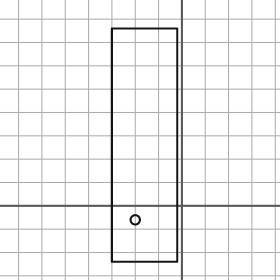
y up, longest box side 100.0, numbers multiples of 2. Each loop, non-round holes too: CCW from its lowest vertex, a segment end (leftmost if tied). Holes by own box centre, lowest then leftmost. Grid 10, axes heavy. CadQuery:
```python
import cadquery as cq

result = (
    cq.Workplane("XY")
    .moveTo(-30.0, -24.0)
    .lineTo(-2.0, -24.0)
    .lineTo(-2.0, 76.0)
    .lineTo(-30.0, 76.0)
    .close()
    .moveTo(-20.0, -6.0)
    .circle(2.0)
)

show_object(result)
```